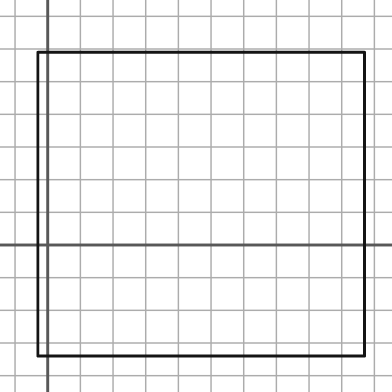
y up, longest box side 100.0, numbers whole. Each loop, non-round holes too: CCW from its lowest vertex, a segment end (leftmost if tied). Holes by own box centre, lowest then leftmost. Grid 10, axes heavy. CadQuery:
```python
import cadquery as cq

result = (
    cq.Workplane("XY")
    .moveTo(-3.0, -34.0)
    .lineTo(97.0, -34.0)
    .lineTo(97.0, 59.0)
    .lineTo(-3.0, 59.0)
    .close()
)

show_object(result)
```